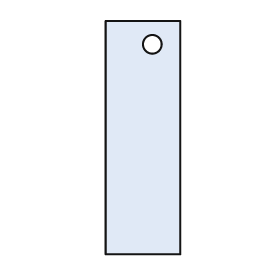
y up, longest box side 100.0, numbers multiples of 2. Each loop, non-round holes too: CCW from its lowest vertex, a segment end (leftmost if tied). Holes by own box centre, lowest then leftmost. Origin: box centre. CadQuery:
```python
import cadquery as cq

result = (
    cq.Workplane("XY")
    .moveTo(-16.0, -50.0)
    .lineTo(16.0, -50.0)
    .lineTo(16.0, 50.0)
    .lineTo(-16.0, 50.0)
    .close()
    .moveTo(4.0, 40.0)
    .circle(4.0)
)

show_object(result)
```